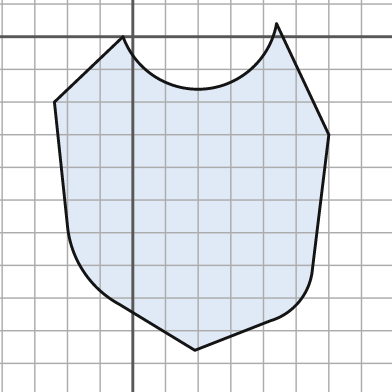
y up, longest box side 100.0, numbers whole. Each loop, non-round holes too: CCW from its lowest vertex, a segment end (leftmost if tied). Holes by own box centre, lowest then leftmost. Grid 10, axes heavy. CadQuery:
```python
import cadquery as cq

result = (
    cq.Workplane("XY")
    .moveTo(19.0, -96.0)
    .lineTo(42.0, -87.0)
    .threePointArc((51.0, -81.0), (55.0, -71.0))
    .lineTo(60.0, -30.0)
    .lineTo(44.0, 4.0)
    .threePointArc((22.0, -16.0), (-3.0, 0.0))
    .lineTo(-24.0, -20.0)
    .lineTo(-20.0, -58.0)
    .threePointArc((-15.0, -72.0), (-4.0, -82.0))
    .close()
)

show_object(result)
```